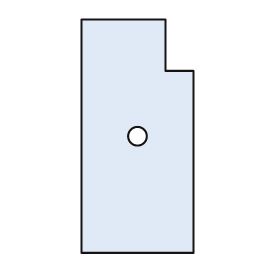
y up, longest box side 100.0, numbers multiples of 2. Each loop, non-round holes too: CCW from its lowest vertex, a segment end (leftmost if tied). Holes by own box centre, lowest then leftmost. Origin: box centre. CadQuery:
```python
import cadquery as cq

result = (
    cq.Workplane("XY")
    .moveTo(-24.0, -50.0)
    .lineTo(24.0, -50.0)
    .lineTo(24.0, 28.0)
    .lineTo(12.0, 28.0)
    .lineTo(12.0, 50.0)
    .lineTo(-24.0, 50.0)
    .close()
    .moveTo(0.0, 0.0)
    .circle(4.0)
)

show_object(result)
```